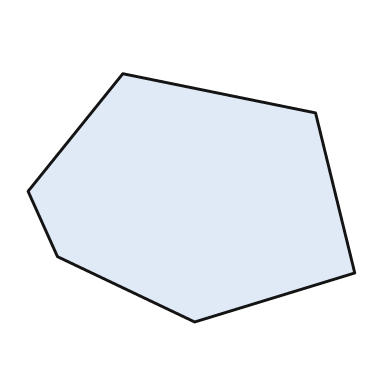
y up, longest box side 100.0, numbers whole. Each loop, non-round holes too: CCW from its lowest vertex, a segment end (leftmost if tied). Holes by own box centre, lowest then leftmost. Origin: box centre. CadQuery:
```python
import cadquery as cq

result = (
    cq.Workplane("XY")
    .moveTo(1.0, -38.0)
    .lineTo(50.0, -23.0)
    .lineTo(38.0, 26.0)
    .lineTo(-21.0, 38.0)
    .lineTo(-50.0, 2.0)
    .lineTo(-41.0, -18.0)
    .close()
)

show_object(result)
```